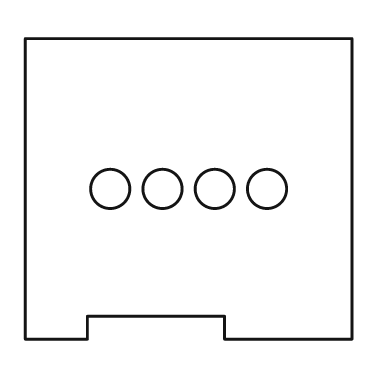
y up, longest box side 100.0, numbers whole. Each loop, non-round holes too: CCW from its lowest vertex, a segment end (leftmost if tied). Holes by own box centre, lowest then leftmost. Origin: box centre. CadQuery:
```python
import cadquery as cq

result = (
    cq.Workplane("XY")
    .moveTo(-50.0, -46.0)
    .lineTo(-31.0, -46.0)
    .lineTo(-31.0, -39.0)
    .lineTo(11.0, -39.0)
    .lineTo(11.0, -46.0)
    .lineTo(50.0, -46.0)
    .lineTo(50.0, 46.0)
    .lineTo(-50.0, 46.0)
    .close()
    .moveTo(-24.0, 0.0)
    .circle(6.0)
    .moveTo(-8.0, 0.0)
    .circle(6.0)
    .moveTo(8.0, 0.0)
    .circle(6.0)
    .moveTo(24.0, 0.0)
    .circle(6.0)
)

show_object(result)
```